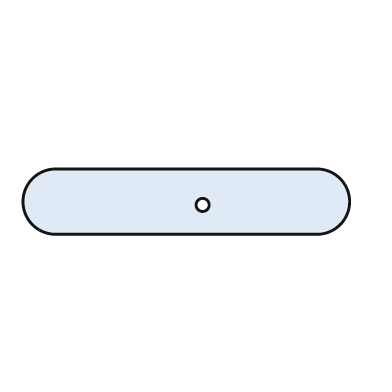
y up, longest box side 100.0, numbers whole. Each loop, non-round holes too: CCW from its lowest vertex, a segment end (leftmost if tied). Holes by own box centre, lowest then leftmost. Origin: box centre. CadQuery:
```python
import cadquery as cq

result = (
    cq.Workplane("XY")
    .moveTo(-40.0, -10.0)
    .lineTo(40.0, -10.0)
    .threePointArc((50.0, 0.0), (40.0, 10.0))
    .lineTo(-40.0, 10.0)
    .threePointArc((-50.0, 0.0), (-40.0, -10.0))
    .close()
    .moveTo(5.0, -1.0)
    .circle(2.0)
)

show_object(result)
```